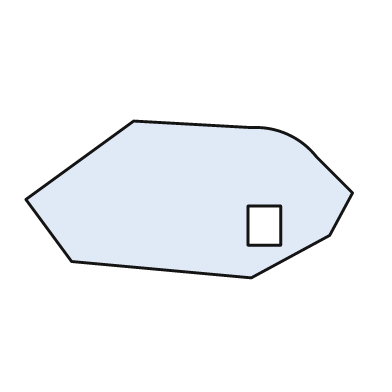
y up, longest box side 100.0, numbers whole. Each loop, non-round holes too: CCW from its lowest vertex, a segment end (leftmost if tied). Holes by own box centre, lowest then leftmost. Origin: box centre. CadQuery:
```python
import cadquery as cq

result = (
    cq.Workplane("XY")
    .moveTo(19.0, -24.0)
    .lineTo(43.0, -11.0)
    .lineTo(50.0, 2.0)
    .lineTo(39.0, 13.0)
    .threePointArc((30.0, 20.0), (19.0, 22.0))
    .lineTo(-17.0, 24.0)
    .lineTo(-50.0, 0.0)
    .lineTo(-36.0, -19.0)
    .close()
    .moveTo(18.0, -14.0)
    .lineTo(28.0, -14.0)
    .lineTo(28.0, -2.0)
    .lineTo(18.0, -2.0)
    .close()
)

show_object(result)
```